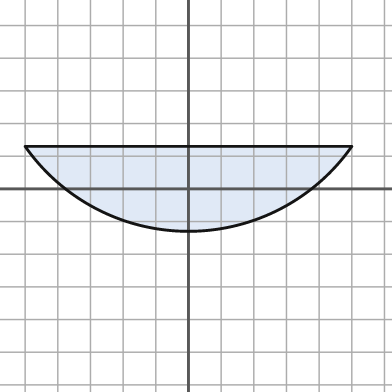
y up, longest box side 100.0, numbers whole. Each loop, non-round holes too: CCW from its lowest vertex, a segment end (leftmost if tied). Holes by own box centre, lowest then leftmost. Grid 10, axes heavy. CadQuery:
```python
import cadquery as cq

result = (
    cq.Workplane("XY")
    .moveTo(-50.0, 13.0)
    .threePointArc((0.0, -13.0), (50.0, 13.0))
    .close()
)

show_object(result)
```